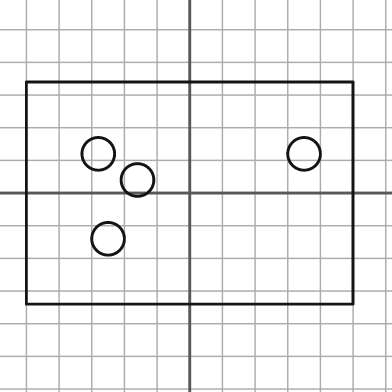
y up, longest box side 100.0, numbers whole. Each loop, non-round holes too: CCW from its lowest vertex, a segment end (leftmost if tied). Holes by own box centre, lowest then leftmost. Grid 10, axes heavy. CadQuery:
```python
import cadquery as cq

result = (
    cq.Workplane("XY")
    .moveTo(-50.0, -34.0)
    .lineTo(50.0, -34.0)
    .lineTo(50.0, 34.0)
    .lineTo(-50.0, 34.0)
    .close()
    .moveTo(-25.0, -14.0)
    .circle(5.0)
    .moveTo(-16.0, 4.0)
    .circle(5.0)
    .moveTo(-28.0, 12.0)
    .circle(5.0)
    .moveTo(35.0, 12.0)
    .circle(5.0)
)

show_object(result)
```